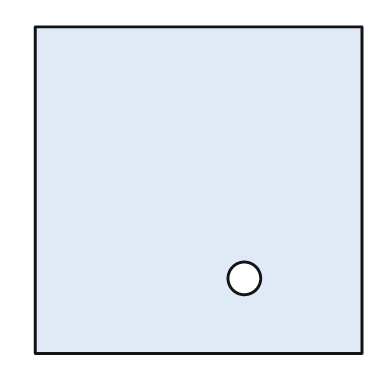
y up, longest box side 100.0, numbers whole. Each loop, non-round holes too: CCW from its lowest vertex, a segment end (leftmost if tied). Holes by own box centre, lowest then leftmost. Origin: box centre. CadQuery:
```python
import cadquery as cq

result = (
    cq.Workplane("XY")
    .moveTo(-50.0, -50.0)
    .lineTo(50.0, -50.0)
    .lineTo(50.0, 50.0)
    .lineTo(-50.0, 50.0)
    .close()
    .moveTo(14.0, -27.0)
    .circle(5.0)
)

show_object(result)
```